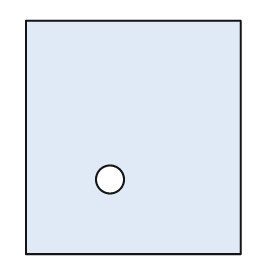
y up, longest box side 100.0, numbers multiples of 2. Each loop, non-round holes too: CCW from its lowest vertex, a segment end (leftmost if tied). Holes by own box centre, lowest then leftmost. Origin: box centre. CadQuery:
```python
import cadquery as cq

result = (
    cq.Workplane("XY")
    .moveTo(-46.0, -50.0)
    .lineTo(46.0, -50.0)
    .lineTo(46.0, 50.0)
    .lineTo(-46.0, 50.0)
    .close()
    .moveTo(-10.0, -18.0)
    .circle(6.0)
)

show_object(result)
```